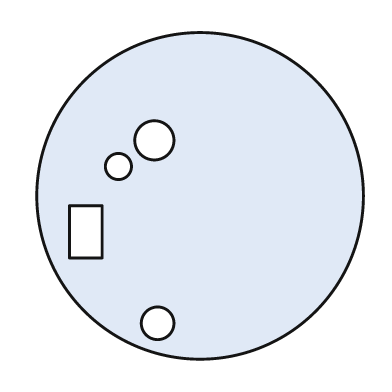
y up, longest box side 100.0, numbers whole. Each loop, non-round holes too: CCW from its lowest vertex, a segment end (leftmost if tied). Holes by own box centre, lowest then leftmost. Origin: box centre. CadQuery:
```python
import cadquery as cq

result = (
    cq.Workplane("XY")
    .moveTo(0.0, 0.0)
    .circle(50.0)
    .moveTo(-13.0, -39.0)
    .circle(5.0)
    .moveTo(-40.0, -19.0)
    .lineTo(-30.0, -19.0)
    .lineTo(-30.0, -3.0)
    .lineTo(-40.0, -3.0)
    .close()
    .moveTo(-25.0, 9.0)
    .circle(4.0)
    .moveTo(-14.0, 17.0)
    .circle(6.0)
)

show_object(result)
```